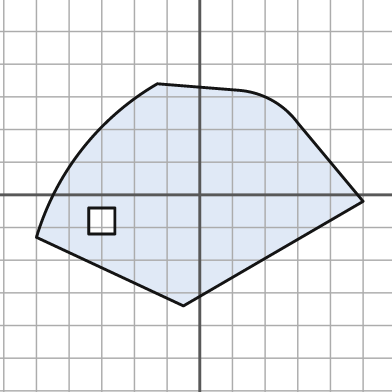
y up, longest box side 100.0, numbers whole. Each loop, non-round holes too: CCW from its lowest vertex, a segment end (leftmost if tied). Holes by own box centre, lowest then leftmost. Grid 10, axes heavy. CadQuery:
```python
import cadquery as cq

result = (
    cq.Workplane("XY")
    .moveTo(-5.0, -34.0)
    .lineTo(50.0, -2.0)
    .lineTo(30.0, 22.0)
    .threePointArc((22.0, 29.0), (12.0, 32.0))
    .lineTo(-13.0, 34.0)
    .threePointArc((-36.0, 14.0), (-50.0, -13.0))
    .close()
    .moveTo(-34.0, -12.0)
    .lineTo(-26.0, -12.0)
    .lineTo(-26.0, -4.0)
    .lineTo(-34.0, -4.0)
    .close()
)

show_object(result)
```